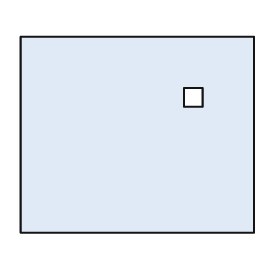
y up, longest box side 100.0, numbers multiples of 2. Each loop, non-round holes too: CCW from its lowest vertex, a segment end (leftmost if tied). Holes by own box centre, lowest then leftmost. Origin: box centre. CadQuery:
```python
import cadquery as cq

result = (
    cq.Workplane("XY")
    .moveTo(-50.0, -42.0)
    .lineTo(50.0, -42.0)
    .lineTo(50.0, 42.0)
    .lineTo(-50.0, 42.0)
    .close()
    .moveTo(20.0, 12.0)
    .lineTo(28.0, 12.0)
    .lineTo(28.0, 20.0)
    .lineTo(20.0, 20.0)
    .close()
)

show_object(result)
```